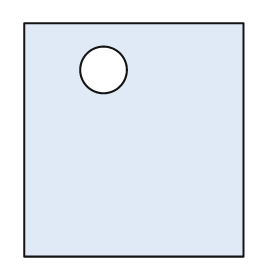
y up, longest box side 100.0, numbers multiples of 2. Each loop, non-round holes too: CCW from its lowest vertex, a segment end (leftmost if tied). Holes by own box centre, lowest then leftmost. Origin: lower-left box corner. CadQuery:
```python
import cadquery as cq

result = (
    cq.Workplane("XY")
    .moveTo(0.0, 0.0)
    .lineTo(94.0, 0.0)
    .lineTo(94.0, 100.0)
    .lineTo(0.0, 100.0)
    .close()
    .moveTo(34.0, 80.0)
    .circle(10.0)
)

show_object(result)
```